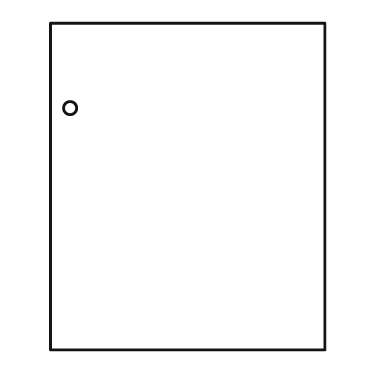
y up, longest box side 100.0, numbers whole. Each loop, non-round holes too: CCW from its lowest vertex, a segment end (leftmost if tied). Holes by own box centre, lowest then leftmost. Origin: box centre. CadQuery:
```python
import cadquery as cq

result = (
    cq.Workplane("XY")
    .moveTo(-42.0, -50.0)
    .lineTo(42.0, -50.0)
    .lineTo(42.0, 50.0)
    .lineTo(-42.0, 50.0)
    .close()
    .moveTo(-36.0, 24.0)
    .circle(2.0)
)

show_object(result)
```